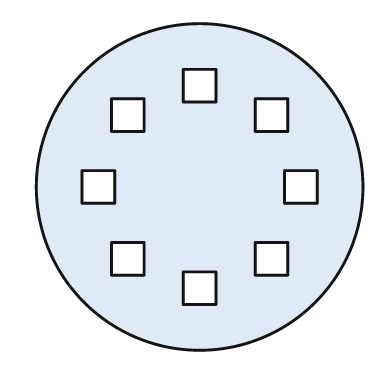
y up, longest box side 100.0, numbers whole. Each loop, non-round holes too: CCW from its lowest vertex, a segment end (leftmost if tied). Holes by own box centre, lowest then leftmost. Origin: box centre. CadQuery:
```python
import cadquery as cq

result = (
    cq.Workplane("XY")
    .moveTo(0.0, 0.0)
    .circle(50.0)
    .moveTo(-5.0, -36.0)
    .lineTo(5.0, -36.0)
    .lineTo(5.0, -26.0)
    .lineTo(-5.0, -26.0)
    .close()
    .moveTo(-27.0, -27.0)
    .lineTo(-17.0, -27.0)
    .lineTo(-17.0, -17.0)
    .lineTo(-27.0, -17.0)
    .close()
    .moveTo(17.0, -27.0)
    .lineTo(27.0, -27.0)
    .lineTo(27.0, -17.0)
    .lineTo(17.0, -17.0)
    .close()
    .moveTo(-36.0, -5.0)
    .lineTo(-26.0, -5.0)
    .lineTo(-26.0, 5.0)
    .lineTo(-36.0, 5.0)
    .close()
    .moveTo(26.0, -5.0)
    .lineTo(36.0, -5.0)
    .lineTo(36.0, 5.0)
    .lineTo(26.0, 5.0)
    .close()
    .moveTo(-27.0, 17.0)
    .lineTo(-17.0, 17.0)
    .lineTo(-17.0, 27.0)
    .lineTo(-27.0, 27.0)
    .close()
    .moveTo(17.0, 17.0)
    .lineTo(27.0, 17.0)
    .lineTo(27.0, 27.0)
    .lineTo(17.0, 27.0)
    .close()
    .moveTo(-5.0, 26.0)
    .lineTo(5.0, 26.0)
    .lineTo(5.0, 36.0)
    .lineTo(-5.0, 36.0)
    .close()
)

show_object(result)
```